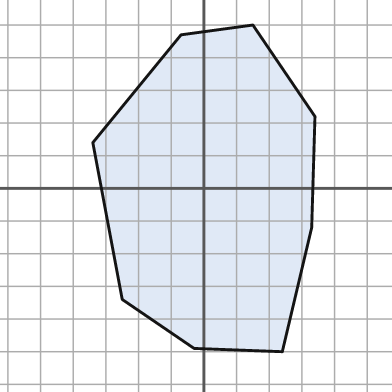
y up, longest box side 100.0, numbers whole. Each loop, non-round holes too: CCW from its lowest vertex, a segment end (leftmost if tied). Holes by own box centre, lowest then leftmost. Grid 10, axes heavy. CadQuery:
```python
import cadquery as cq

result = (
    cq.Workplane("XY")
    .moveTo(24.0, -50.0)
    .lineTo(33.0, -12.0)
    .lineTo(34.0, 22.0)
    .lineTo(15.0, 50.0)
    .lineTo(-7.0, 47.0)
    .lineTo(-34.0, 14.0)
    .lineTo(-25.0, -34.0)
    .lineTo(-3.0, -49.0)
    .close()
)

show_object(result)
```